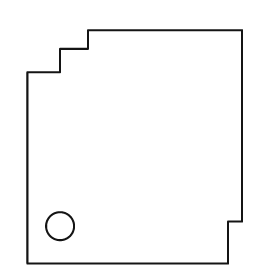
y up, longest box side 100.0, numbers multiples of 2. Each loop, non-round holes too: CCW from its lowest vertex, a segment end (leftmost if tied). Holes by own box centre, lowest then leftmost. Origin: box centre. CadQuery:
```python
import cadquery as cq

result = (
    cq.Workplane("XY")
    .moveTo(-46.0, -50.0)
    .lineTo(40.0, -50.0)
    .lineTo(40.0, -32.0)
    .lineTo(46.0, -32.0)
    .lineTo(46.0, 50.0)
    .lineTo(-20.0, 50.0)
    .lineTo(-20.0, 42.0)
    .lineTo(-32.0, 42.0)
    .lineTo(-32.0, 32.0)
    .lineTo(-46.0, 32.0)
    .close()
    .moveTo(-32.0, -34.0)
    .circle(6.0)
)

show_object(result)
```